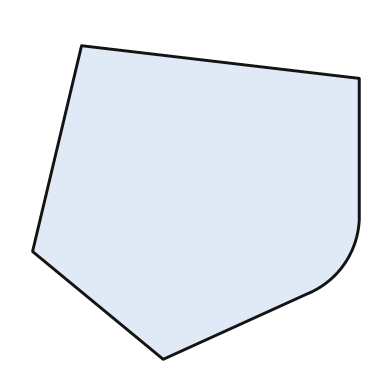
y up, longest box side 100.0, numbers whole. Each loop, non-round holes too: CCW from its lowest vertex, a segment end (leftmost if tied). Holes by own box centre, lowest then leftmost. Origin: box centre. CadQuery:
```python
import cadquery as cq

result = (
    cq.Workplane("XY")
    .moveTo(-10.0, -48.0)
    .lineTo(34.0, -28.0)
    .threePointArc((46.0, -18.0), (50.0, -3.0))
    .lineTo(50.0, 38.0)
    .lineTo(-35.0, 48.0)
    .lineTo(-50.0, -15.0)
    .close()
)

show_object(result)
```